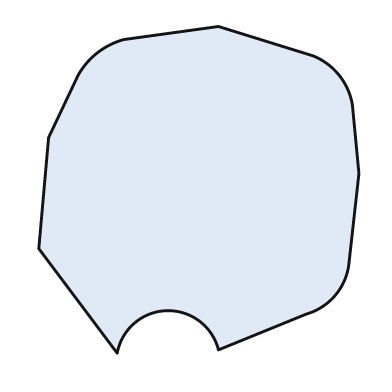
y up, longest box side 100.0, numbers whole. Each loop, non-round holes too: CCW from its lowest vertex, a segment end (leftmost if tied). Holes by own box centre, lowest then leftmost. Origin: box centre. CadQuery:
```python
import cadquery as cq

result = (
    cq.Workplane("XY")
    .moveTo(-25.0, -50.0)
    .threePointArc((-10.0, -37.0), (6.0, -49.0))
    .lineTo(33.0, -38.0)
    .threePointArc((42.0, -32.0), (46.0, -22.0))
    .lineTo(49.0, 5.0)
    .lineTo(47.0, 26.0)
    .threePointArc((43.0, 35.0), (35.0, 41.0))
    .lineTo(6.0, 50.0)
    .lineTo(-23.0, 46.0)
    .threePointArc((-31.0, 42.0), (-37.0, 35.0))
    .lineTo(-46.0, 16.0)
    .lineTo(-49.0, -18.0)
    .close()
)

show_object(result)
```